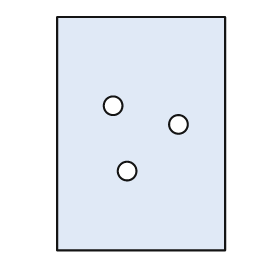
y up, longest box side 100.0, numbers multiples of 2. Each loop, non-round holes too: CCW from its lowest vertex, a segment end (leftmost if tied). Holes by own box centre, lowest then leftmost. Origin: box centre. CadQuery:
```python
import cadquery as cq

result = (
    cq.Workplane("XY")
    .moveTo(-36.0, -50.0)
    .lineTo(36.0, -50.0)
    .lineTo(36.0, 50.0)
    .lineTo(-36.0, 50.0)
    .close()
    .moveTo(-6.0, -16.0)
    .circle(4.0)
    .moveTo(16.0, 4.0)
    .circle(4.0)
    .moveTo(-12.0, 12.0)
    .circle(4.0)
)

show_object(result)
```